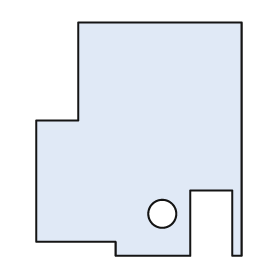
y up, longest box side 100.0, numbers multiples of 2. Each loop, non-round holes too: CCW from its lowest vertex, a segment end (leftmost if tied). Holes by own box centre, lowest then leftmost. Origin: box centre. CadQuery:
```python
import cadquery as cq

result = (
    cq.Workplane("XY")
    .moveTo(-10.0, -50.0)
    .lineTo(22.0, -50.0)
    .lineTo(22.0, -22.0)
    .lineTo(40.0, -22.0)
    .lineTo(40.0, -50.0)
    .lineTo(44.0, -50.0)
    .lineTo(44.0, 50.0)
    .lineTo(-26.0, 50.0)
    .lineTo(-26.0, 8.0)
    .lineTo(-44.0, 8.0)
    .lineTo(-44.0, -44.0)
    .lineTo(-10.0, -44.0)
    .close()
    .moveTo(10.0, -32.0)
    .circle(6.0)
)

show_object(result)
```